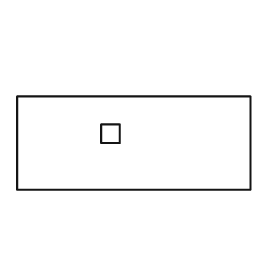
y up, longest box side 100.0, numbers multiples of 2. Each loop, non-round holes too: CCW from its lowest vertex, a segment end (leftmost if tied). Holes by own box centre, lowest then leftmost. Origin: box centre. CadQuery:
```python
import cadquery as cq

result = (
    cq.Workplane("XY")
    .moveTo(-50.0, -20.0)
    .lineTo(50.0, -20.0)
    .lineTo(50.0, 20.0)
    .lineTo(-50.0, 20.0)
    .close()
    .moveTo(-14.0, 0.0)
    .lineTo(-6.0, 0.0)
    .lineTo(-6.0, 8.0)
    .lineTo(-14.0, 8.0)
    .close()
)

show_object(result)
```